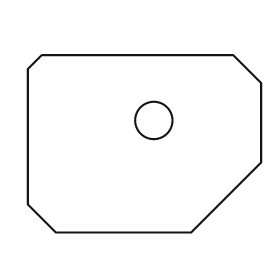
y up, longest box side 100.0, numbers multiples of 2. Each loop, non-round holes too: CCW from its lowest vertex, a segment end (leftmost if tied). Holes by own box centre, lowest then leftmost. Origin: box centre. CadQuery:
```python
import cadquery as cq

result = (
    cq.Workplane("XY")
    .moveTo(-38.0, -38.0)
    .lineTo(20.0, -38.0)
    .lineTo(50.0, -8.0)
    .lineTo(50.0, 26.0)
    .lineTo(38.0, 38.0)
    .lineTo(-44.0, 38.0)
    .lineTo(-50.0, 32.0)
    .lineTo(-50.0, -26.0)
    .close()
    .moveTo(4.0, 10.0)
    .circle(8.0)
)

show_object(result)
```